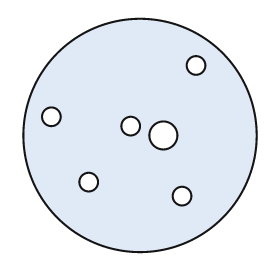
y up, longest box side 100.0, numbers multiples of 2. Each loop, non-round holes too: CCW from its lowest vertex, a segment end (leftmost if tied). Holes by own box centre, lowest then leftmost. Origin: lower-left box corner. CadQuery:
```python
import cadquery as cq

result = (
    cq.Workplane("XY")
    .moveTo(50.0, 50.0)
    .circle(50.0)
    .moveTo(68.0, 24.0)
    .circle(4.0)
    .moveTo(28.0, 30.0)
    .circle(4.0)
    .moveTo(60.0, 50.0)
    .circle(6.0)
    .moveTo(46.0, 54.0)
    .circle(4.0)
    .moveTo(12.0, 58.0)
    .circle(4.0)
    .moveTo(74.0, 80.0)
    .circle(4.0)
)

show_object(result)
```